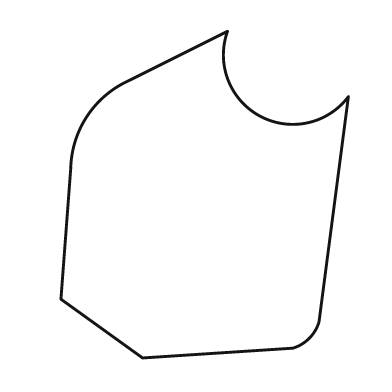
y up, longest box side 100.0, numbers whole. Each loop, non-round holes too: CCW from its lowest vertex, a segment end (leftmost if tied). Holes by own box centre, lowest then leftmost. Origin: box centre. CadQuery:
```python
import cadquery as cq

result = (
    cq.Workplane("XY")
    .moveTo(-19.0, -50.0)
    .lineTo(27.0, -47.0)
    .threePointArc((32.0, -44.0), (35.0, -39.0))
    .lineTo(44.0, 30.0)
    .threePointArc((17.0, 24.0), (7.0, 50.0))
    .lineTo(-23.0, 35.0)
    .threePointArc((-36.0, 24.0), (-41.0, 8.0))
    .lineTo(-44.0, -32.0)
    .close()
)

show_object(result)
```